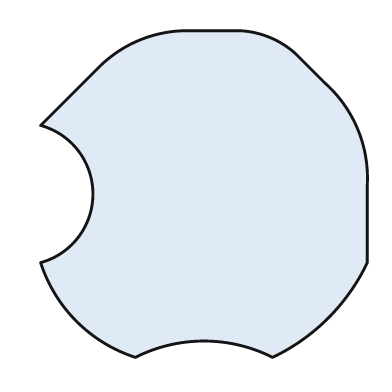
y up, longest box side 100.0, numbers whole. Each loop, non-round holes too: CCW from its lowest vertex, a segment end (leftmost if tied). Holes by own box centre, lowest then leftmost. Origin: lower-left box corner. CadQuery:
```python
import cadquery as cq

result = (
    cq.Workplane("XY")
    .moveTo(29.0, 0.0)
    .threePointArc((50.0, 5.0), (71.0, 0.0))
    .threePointArc((88.0, 12.0), (100.0, 29.0))
    .lineTo(100.0, 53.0)
    .threePointArc((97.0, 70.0), (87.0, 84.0))
    .lineTo(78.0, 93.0)
    .threePointArc((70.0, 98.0), (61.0, 100.0))
    .lineTo(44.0, 100.0)
    .threePointArc((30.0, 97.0), (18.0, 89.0))
    .lineTo(0.0, 71.0)
    .threePointArc((16.0, 50.0), (0.0, 29.0))
    .threePointArc((11.0, 11.0), (29.0, 0.0))
    .close()
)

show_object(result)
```